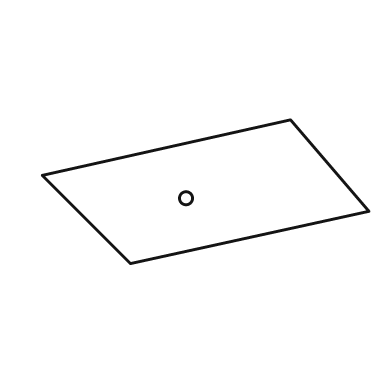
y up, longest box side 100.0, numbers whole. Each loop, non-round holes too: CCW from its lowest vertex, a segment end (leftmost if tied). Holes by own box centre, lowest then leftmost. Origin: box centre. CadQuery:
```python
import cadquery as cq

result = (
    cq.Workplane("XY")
    .moveTo(-23.0, -22.0)
    .lineTo(50.0, -6.0)
    .lineTo(26.0, 22.0)
    .lineTo(-50.0, 5.0)
    .close()
    .moveTo(-6.0, -2.0)
    .circle(2.0)
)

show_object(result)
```